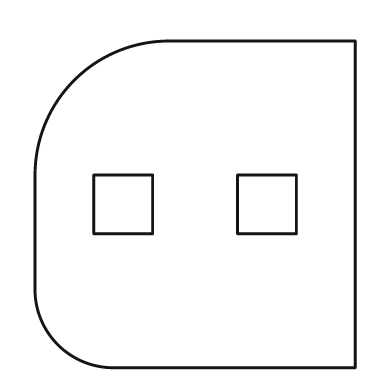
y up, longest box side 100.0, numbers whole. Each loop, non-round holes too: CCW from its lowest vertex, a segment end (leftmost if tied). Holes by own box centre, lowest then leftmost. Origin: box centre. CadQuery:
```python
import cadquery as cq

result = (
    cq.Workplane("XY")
    .moveTo(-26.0, -50.0)
    .lineTo(49.0, -50.0)
    .lineTo(49.0, 50.0)
    .lineTo(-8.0, 50.0)
    .threePointArc((-37.0, 38.0), (-49.0, 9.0))
    .lineTo(-49.0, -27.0)
    .threePointArc((-42.0, -43.0), (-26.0, -50.0))
    .close()
    .moveTo(-31.0, -9.0)
    .lineTo(-13.0, -9.0)
    .lineTo(-13.0, 9.0)
    .lineTo(-31.0, 9.0)
    .close()
    .moveTo(13.0, -9.0)
    .lineTo(31.0, -9.0)
    .lineTo(31.0, 9.0)
    .lineTo(13.0, 9.0)
    .close()
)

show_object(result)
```